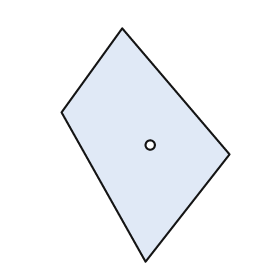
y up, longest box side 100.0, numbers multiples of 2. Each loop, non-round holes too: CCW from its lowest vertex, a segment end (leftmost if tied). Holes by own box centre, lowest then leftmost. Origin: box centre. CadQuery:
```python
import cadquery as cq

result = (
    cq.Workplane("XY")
    .moveTo(0.0, -50.0)
    .lineTo(36.0, -4.0)
    .lineTo(-10.0, 50.0)
    .lineTo(-36.0, 14.0)
    .close()
    .moveTo(2.0, 0.0)
    .circle(2.0)
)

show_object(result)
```